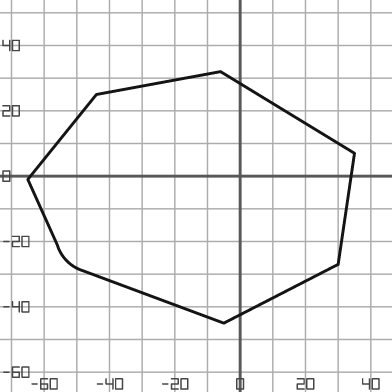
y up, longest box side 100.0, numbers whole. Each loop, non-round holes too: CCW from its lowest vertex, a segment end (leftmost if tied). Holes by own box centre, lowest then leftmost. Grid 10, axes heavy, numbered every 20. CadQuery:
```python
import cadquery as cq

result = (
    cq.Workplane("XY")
    .moveTo(-5.0, -45.0)
    .lineTo(30.0, -27.0)
    .lineTo(35.0, 7.0)
    .lineTo(-6.0, 32.0)
    .lineTo(-44.0, 25.0)
    .lineTo(-65.0, -1.0)
    .lineTo(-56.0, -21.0)
    .threePointArc((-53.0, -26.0), (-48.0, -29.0))
    .close()
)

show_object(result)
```